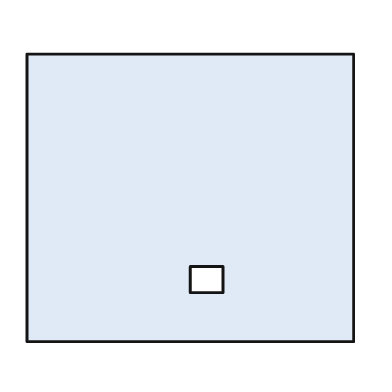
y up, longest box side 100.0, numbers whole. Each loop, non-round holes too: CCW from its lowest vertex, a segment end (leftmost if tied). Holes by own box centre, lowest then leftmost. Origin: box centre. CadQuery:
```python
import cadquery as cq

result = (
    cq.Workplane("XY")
    .moveTo(-50.0, -44.0)
    .lineTo(50.0, -44.0)
    .lineTo(50.0, 44.0)
    .lineTo(-50.0, 44.0)
    .close()
    .moveTo(0.0, -29.0)
    .lineTo(10.0, -29.0)
    .lineTo(10.0, -21.0)
    .lineTo(0.0, -21.0)
    .close()
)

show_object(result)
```